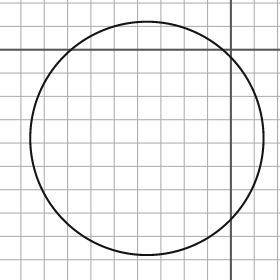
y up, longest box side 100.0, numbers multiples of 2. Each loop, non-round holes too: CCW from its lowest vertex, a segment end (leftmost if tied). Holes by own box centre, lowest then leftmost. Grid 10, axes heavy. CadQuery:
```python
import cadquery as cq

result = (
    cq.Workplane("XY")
    .moveTo(-36.0, -38.0)
    .circle(50.0)
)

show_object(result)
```